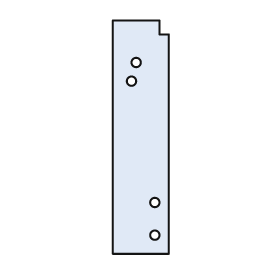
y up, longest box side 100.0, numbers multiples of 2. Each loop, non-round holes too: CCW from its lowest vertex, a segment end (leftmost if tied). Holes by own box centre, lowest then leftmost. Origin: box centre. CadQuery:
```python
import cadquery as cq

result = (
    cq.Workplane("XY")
    .moveTo(-12.0, -50.0)
    .lineTo(12.0, -50.0)
    .lineTo(12.0, 44.0)
    .lineTo(8.0, 44.0)
    .lineTo(8.0, 50.0)
    .lineTo(-12.0, 50.0)
    .close()
    .moveTo(6.0, -42.0)
    .circle(2.0)
    .moveTo(6.0, -28.0)
    .circle(2.0)
    .moveTo(-4.0, 24.0)
    .circle(2.0)
    .moveTo(-2.0, 32.0)
    .circle(2.0)
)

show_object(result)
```